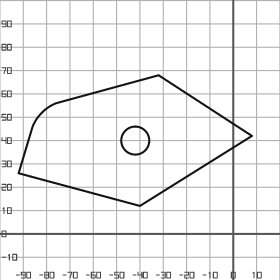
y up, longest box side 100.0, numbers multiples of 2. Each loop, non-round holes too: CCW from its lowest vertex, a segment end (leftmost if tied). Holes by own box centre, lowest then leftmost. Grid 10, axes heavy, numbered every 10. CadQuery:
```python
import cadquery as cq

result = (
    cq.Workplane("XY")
    .moveTo(-40.0, 12.0)
    .lineTo(8.0, 42.0)
    .lineTo(-32.0, 68.0)
    .lineTo(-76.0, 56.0)
    .threePointArc((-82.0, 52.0), (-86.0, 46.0))
    .lineTo(-92.0, 26.0)
    .close()
    .moveTo(-42.0, 40.0)
    .circle(6.0)
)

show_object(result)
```